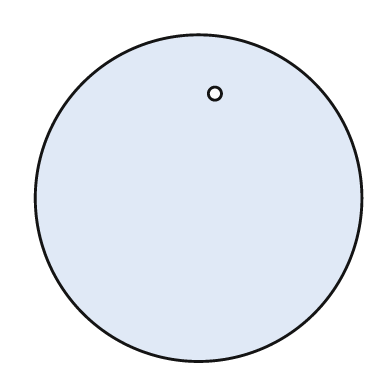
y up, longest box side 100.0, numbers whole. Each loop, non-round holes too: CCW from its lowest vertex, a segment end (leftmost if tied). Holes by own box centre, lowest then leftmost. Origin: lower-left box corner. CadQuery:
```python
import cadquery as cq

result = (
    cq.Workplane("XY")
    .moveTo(50.0, 50.0)
    .circle(50.0)
    .moveTo(55.0, 82.0)
    .circle(2.0)
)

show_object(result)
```